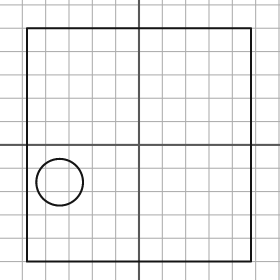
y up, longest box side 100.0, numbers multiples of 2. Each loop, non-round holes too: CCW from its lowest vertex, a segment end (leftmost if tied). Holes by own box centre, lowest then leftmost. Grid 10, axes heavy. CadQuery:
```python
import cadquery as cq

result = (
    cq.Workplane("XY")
    .moveTo(-48.0, -50.0)
    .lineTo(48.0, -50.0)
    .lineTo(48.0, 50.0)
    .lineTo(-48.0, 50.0)
    .close()
    .moveTo(-34.0, -16.0)
    .circle(10.0)
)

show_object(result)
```